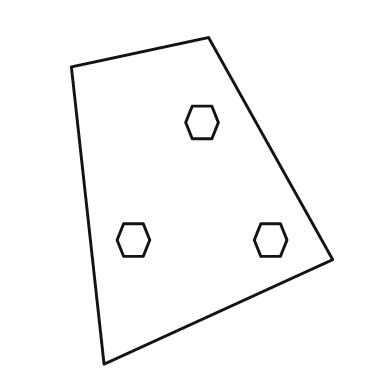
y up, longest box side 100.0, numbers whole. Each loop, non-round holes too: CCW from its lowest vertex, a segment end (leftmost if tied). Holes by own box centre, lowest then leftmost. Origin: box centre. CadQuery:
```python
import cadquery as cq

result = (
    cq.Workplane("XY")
    .moveTo(-30.0, -50.0)
    .lineTo(40.0, -18.0)
    .lineTo(2.0, 50.0)
    .lineTo(-40.0, 41.0)
    .close()
    .moveTo(-24.0, -17.0)
    .lineTo(-18.0, -17.0)
    .lineTo(-16.0, -12.0)
    .lineTo(-18.0, -7.0)
    .lineTo(-24.0, -7.0)
    .lineTo(-26.0, -12.0)
    .close()
    .moveTo(18.0, -17.0)
    .lineTo(24.0, -17.0)
    .lineTo(26.0, -12.0)
    .lineTo(24.0, -7.0)
    .lineTo(18.0, -7.0)
    .lineTo(16.0, -12.0)
    .close()
    .moveTo(-3.0, 19.0)
    .lineTo(3.0, 19.0)
    .lineTo(5.0, 24.0)
    .lineTo(3.0, 29.0)
    .lineTo(-3.0, 29.0)
    .lineTo(-5.0, 24.0)
    .close()
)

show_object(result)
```